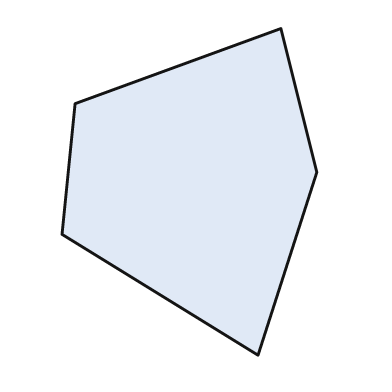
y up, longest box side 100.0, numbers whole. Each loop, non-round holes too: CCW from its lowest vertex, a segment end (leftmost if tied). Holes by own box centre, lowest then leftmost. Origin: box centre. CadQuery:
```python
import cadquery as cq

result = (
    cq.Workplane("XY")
    .moveTo(21.0, -50.0)
    .lineTo(39.0, 6.0)
    .lineTo(28.0, 50.0)
    .lineTo(-35.0, 27.0)
    .lineTo(-39.0, -13.0)
    .close()
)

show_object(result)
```